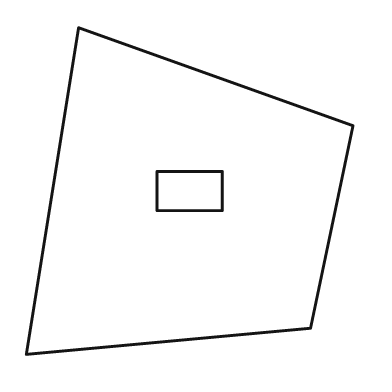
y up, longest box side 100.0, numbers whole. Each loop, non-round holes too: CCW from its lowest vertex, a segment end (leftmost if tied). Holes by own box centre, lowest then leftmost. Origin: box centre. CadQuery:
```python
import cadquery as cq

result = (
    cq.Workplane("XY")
    .moveTo(-50.0, -50.0)
    .lineTo(37.0, -42.0)
    .lineTo(50.0, 20.0)
    .lineTo(-34.0, 50.0)
    .close()
    .moveTo(-10.0, -6.0)
    .lineTo(10.0, -6.0)
    .lineTo(10.0, 6.0)
    .lineTo(-10.0, 6.0)
    .close()
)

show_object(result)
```